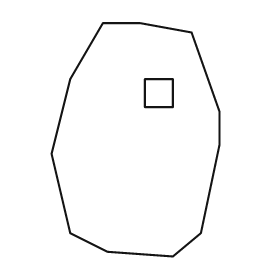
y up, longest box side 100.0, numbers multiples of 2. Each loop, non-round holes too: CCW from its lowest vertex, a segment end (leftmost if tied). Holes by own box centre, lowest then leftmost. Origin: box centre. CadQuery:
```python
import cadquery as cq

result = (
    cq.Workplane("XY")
    .moveTo(16.0, -50.0)
    .lineTo(28.0, -40.0)
    .lineTo(36.0, -2.0)
    .lineTo(36.0, 12.0)
    .lineTo(24.0, 46.0)
    .lineTo(2.0, 50.0)
    .lineTo(-14.0, 50.0)
    .lineTo(-28.0, 26.0)
    .lineTo(-36.0, -6.0)
    .lineTo(-28.0, -40.0)
    .lineTo(-12.0, -48.0)
    .close()
    .moveTo(4.0, 14.0)
    .lineTo(16.0, 14.0)
    .lineTo(16.0, 26.0)
    .lineTo(4.0, 26.0)
    .close()
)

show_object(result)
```